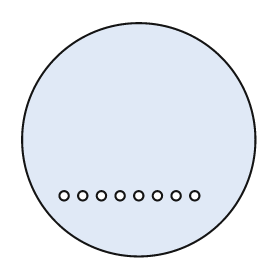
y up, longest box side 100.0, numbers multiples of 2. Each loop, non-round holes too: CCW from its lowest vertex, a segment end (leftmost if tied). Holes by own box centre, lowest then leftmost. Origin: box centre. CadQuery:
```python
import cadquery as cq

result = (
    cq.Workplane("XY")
    .moveTo(0.0, 0.0)
    .circle(50.0)
    .moveTo(-32.0, -24.0)
    .circle(2.0)
    .moveTo(-24.0, -24.0)
    .circle(2.0)
    .moveTo(-16.0, -24.0)
    .circle(2.0)
    .moveTo(-8.0, -24.0)
    .circle(2.0)
    .moveTo(0.0, -24.0)
    .circle(2.0)
    .moveTo(8.0, -24.0)
    .circle(2.0)
    .moveTo(16.0, -24.0)
    .circle(2.0)
    .moveTo(24.0, -24.0)
    .circle(2.0)
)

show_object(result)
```